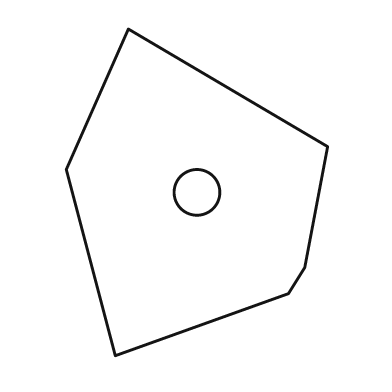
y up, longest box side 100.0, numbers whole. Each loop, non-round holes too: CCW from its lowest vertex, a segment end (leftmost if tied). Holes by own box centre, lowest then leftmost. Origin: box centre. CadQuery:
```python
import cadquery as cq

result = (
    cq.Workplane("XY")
    .moveTo(-25.0, -50.0)
    .lineTo(28.0, -31.0)
    .lineTo(33.0, -23.0)
    .lineTo(40.0, 14.0)
    .lineTo(-21.0, 50.0)
    .lineTo(-40.0, 7.0)
    .close()
    .moveTo(0.0, 0.0)
    .circle(7.0)
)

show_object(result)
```